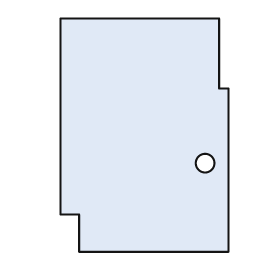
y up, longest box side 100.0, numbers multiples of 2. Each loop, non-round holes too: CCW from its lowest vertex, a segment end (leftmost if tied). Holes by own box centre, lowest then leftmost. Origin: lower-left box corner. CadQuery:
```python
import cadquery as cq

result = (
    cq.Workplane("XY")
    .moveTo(8.0, 0.0)
    .lineTo(72.0, 0.0)
    .lineTo(72.0, 70.0)
    .lineTo(68.0, 70.0)
    .lineTo(68.0, 100.0)
    .lineTo(0.0, 100.0)
    .lineTo(0.0, 16.0)
    .lineTo(8.0, 16.0)
    .close()
    .moveTo(62.0, 38.0)
    .circle(4.0)
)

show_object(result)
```